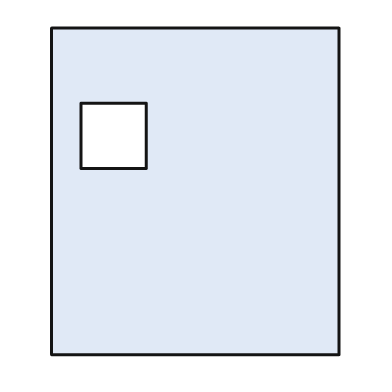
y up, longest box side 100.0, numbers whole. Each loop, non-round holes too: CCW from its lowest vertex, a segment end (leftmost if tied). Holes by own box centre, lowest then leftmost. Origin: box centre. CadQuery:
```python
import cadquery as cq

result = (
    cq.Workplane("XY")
    .moveTo(-44.0, -50.0)
    .lineTo(44.0, -50.0)
    .lineTo(44.0, 50.0)
    .lineTo(-44.0, 50.0)
    .close()
    .moveTo(-35.0, 7.0)
    .lineTo(-15.0, 7.0)
    .lineTo(-15.0, 27.0)
    .lineTo(-35.0, 27.0)
    .close()
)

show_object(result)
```